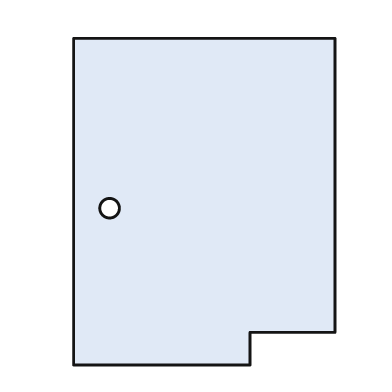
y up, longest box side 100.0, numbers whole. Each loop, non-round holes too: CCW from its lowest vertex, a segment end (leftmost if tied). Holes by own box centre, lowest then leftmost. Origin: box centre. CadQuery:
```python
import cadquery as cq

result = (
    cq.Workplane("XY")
    .moveTo(-40.0, -50.0)
    .lineTo(14.0, -50.0)
    .lineTo(14.0, -40.0)
    .lineTo(40.0, -40.0)
    .lineTo(40.0, 50.0)
    .lineTo(-40.0, 50.0)
    .close()
    .moveTo(-29.0, -2.0)
    .circle(3.0)
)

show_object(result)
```